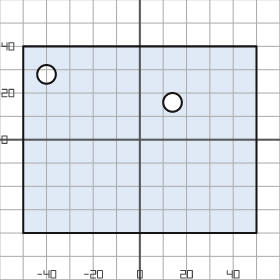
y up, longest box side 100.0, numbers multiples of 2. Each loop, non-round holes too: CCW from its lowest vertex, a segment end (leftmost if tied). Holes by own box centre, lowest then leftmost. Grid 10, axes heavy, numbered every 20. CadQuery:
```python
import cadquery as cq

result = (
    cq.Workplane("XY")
    .moveTo(-50.0, -40.0)
    .lineTo(50.0, -40.0)
    .lineTo(50.0, 40.0)
    .lineTo(-50.0, 40.0)
    .close()
    .moveTo(14.0, 16.0)
    .circle(4.0)
    .moveTo(-40.0, 28.0)
    .circle(4.0)
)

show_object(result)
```